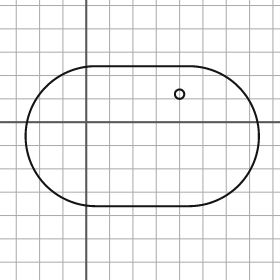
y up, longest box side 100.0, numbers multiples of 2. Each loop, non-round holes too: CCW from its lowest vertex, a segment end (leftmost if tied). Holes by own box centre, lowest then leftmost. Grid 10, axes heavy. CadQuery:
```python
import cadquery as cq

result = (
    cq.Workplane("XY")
    .moveTo(4.0, -36.0)
    .lineTo(44.0, -36.0)
    .threePointArc((74.0, -6.0), (44.0, 24.0))
    .lineTo(4.0, 24.0)
    .threePointArc((-26.0, -6.0), (4.0, -36.0))
    .close()
    .moveTo(40.0, 12.0)
    .circle(2.0)
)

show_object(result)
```